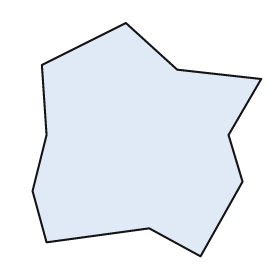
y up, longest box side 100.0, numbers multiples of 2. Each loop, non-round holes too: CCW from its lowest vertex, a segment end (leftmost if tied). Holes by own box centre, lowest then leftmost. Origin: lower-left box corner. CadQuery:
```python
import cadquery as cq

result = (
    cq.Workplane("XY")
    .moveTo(72.0, 0.0)
    .lineTo(90.0, 32.0)
    .lineTo(84.0, 52.0)
    .lineTo(98.0, 76.0)
    .lineTo(62.0, 80.0)
    .lineTo(40.0, 100.0)
    .lineTo(4.0, 82.0)
    .lineTo(6.0, 52.0)
    .lineTo(0.0, 28.0)
    .lineTo(6.0, 6.0)
    .lineTo(50.0, 12.0)
    .close()
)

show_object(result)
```